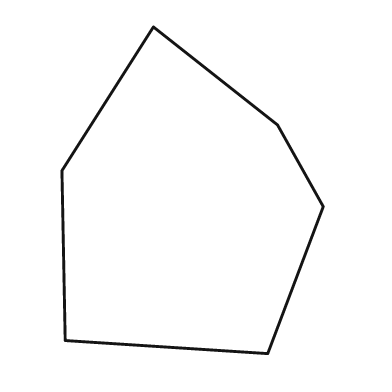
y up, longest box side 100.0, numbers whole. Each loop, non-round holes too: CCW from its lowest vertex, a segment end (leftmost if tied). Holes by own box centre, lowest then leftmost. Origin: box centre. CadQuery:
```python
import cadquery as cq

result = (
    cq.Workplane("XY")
    .moveTo(23.0, -50.0)
    .lineTo(40.0, -5.0)
    .lineTo(26.0, 20.0)
    .lineTo(-12.0, 50.0)
    .lineTo(-40.0, 6.0)
    .lineTo(-39.0, -46.0)
    .close()
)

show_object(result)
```